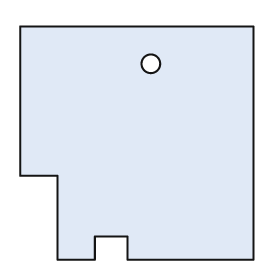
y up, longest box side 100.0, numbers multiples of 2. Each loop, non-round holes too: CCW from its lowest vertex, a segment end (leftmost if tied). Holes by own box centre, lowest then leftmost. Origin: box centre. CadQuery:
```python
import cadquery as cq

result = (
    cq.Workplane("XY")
    .moveTo(-34.0, -50.0)
    .lineTo(-18.0, -50.0)
    .lineTo(-18.0, -40.0)
    .lineTo(-4.0, -40.0)
    .lineTo(-4.0, -50.0)
    .lineTo(50.0, -50.0)
    .lineTo(50.0, 50.0)
    .lineTo(-50.0, 50.0)
    .lineTo(-50.0, -14.0)
    .lineTo(-34.0, -14.0)
    .close()
    .moveTo(6.0, 34.0)
    .circle(4.0)
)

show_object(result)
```